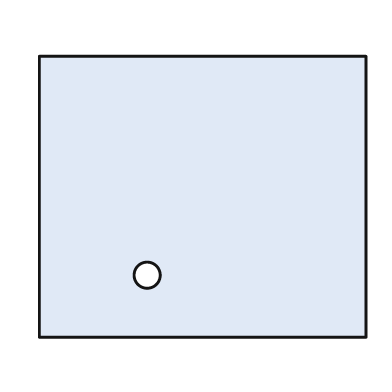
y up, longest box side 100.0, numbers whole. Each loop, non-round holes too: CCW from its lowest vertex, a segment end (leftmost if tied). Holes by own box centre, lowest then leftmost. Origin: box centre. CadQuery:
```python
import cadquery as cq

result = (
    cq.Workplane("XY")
    .moveTo(-50.0, -43.0)
    .lineTo(50.0, -43.0)
    .lineTo(50.0, 43.0)
    .lineTo(-50.0, 43.0)
    .close()
    .moveTo(-17.0, -24.0)
    .circle(4.0)
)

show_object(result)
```